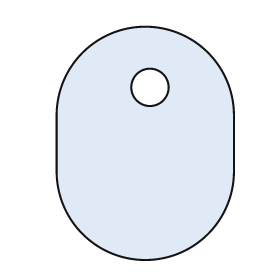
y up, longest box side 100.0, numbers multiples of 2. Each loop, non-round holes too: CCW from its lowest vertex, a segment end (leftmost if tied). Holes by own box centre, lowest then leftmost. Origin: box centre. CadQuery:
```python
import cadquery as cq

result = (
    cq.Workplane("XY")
    .moveTo(-38.0, -12.0)
    .threePointArc((0.0, -50.0), (38.0, -12.0))
    .lineTo(38.0, 12.0)
    .threePointArc((0.0, 50.0), (-38.0, 12.0))
    .close()
    .moveTo(2.0, 24.0)
    .circle(8.0)
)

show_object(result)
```